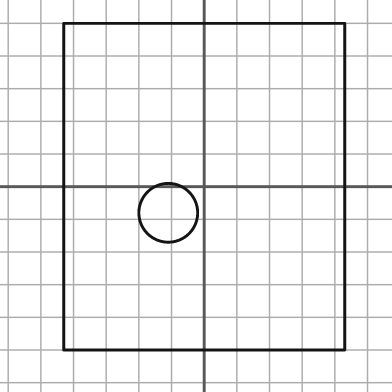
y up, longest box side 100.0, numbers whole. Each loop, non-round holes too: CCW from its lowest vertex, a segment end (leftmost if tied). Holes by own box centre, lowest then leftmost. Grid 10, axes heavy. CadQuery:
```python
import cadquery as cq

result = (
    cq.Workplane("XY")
    .moveTo(-43.0, -50.0)
    .lineTo(43.0, -50.0)
    .lineTo(43.0, 50.0)
    .lineTo(-43.0, 50.0)
    .close()
    .moveTo(-11.0, -8.0)
    .circle(9.0)
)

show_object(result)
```